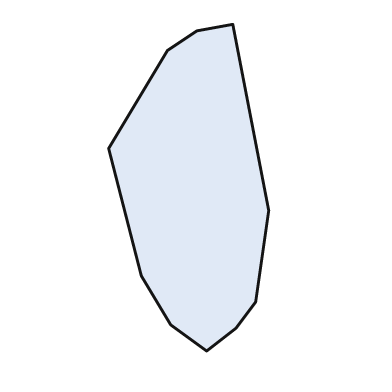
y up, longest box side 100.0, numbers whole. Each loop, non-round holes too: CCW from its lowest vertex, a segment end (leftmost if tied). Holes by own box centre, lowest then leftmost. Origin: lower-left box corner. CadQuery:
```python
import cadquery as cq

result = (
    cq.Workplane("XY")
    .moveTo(30.0, 0.0)
    .lineTo(39.0, 7.0)
    .lineTo(45.0, 15.0)
    .lineTo(49.0, 43.0)
    .lineTo(38.0, 100.0)
    .lineTo(27.0, 98.0)
    .lineTo(18.0, 92.0)
    .lineTo(0.0, 62.0)
    .lineTo(10.0, 23.0)
    .lineTo(19.0, 8.0)
    .close()
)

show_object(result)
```